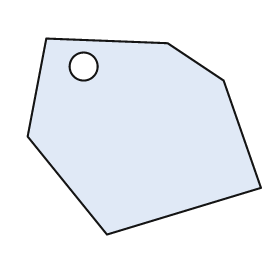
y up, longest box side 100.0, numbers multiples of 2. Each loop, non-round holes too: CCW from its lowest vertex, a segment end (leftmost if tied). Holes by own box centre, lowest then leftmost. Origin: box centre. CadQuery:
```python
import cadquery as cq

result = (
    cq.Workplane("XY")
    .moveTo(-16.0, -42.0)
    .lineTo(50.0, -22.0)
    .lineTo(34.0, 24.0)
    .lineTo(10.0, 40.0)
    .lineTo(-42.0, 42.0)
    .lineTo(-50.0, 0.0)
    .close()
    .moveTo(-26.0, 30.0)
    .circle(6.0)
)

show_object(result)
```